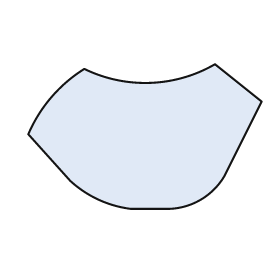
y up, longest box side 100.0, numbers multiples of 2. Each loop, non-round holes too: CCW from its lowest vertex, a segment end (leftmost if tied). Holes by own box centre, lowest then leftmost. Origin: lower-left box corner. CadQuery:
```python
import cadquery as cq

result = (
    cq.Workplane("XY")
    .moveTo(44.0, 0.0)
    .lineTo(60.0, 0.0)
    .threePointArc((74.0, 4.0), (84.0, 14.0))
    .lineTo(100.0, 46.0)
    .lineTo(80.0, 62.0)
    .threePointArc((52.0, 54.0), (24.0, 60.0))
    .threePointArc((10.0, 48.0), (0.0, 32.0))
    .lineTo(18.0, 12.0)
    .threePointArc((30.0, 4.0), (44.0, 0.0))
    .close()
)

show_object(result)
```